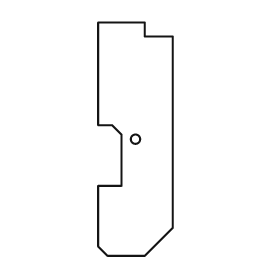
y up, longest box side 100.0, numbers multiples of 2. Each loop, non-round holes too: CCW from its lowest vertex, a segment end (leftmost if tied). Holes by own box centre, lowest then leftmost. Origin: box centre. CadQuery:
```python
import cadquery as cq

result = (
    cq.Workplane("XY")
    .moveTo(-12.0, -50.0)
    .lineTo(4.0, -50.0)
    .lineTo(16.0, -38.0)
    .lineTo(16.0, 44.0)
    .lineTo(4.0, 44.0)
    .lineTo(4.0, 50.0)
    .lineTo(-16.0, 50.0)
    .lineTo(-16.0, 6.0)
    .lineTo(-10.0, 6.0)
    .lineTo(-6.0, 2.0)
    .lineTo(-6.0, -20.0)
    .lineTo(-16.0, -20.0)
    .lineTo(-16.0, -46.0)
    .close()
    .moveTo(0.0, 0.0)
    .circle(2.0)
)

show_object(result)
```